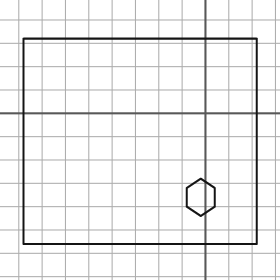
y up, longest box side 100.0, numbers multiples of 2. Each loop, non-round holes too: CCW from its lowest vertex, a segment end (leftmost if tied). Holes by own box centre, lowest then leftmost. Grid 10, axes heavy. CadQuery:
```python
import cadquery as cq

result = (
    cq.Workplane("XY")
    .moveTo(-78.0, -56.0)
    .lineTo(22.0, -56.0)
    .lineTo(22.0, 32.0)
    .lineTo(-78.0, 32.0)
    .close()
    .moveTo(-2.0, -44.0)
    .lineTo(4.0, -40.0)
    .lineTo(4.0, -32.0)
    .lineTo(-2.0, -28.0)
    .lineTo(-8.0, -32.0)
    .lineTo(-8.0, -40.0)
    .close()
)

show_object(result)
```